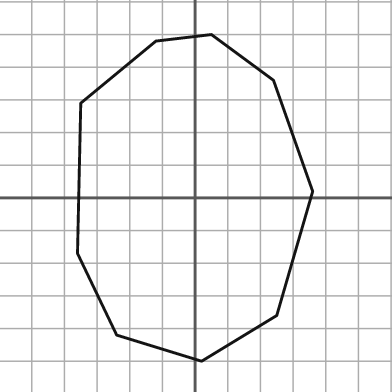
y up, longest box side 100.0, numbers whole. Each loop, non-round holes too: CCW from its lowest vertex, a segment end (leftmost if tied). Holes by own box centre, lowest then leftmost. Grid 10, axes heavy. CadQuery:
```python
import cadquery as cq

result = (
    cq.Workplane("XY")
    .moveTo(2.0, -50.0)
    .lineTo(25.0, -36.0)
    .lineTo(36.0, 2.0)
    .lineTo(24.0, 36.0)
    .lineTo(5.0, 50.0)
    .lineTo(-12.0, 48.0)
    .lineTo(-35.0, 29.0)
    .lineTo(-36.0, -17.0)
    .lineTo(-24.0, -42.0)
    .close()
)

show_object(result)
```